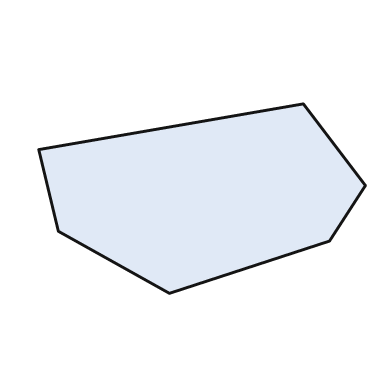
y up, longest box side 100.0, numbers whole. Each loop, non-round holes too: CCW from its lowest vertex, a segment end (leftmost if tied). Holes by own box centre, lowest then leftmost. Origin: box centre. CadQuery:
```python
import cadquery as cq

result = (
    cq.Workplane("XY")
    .moveTo(-10.0, -29.0)
    .lineTo(39.0, -13.0)
    .lineTo(50.0, 4.0)
    .lineTo(31.0, 29.0)
    .lineTo(-50.0, 15.0)
    .lineTo(-44.0, -10.0)
    .close()
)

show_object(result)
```